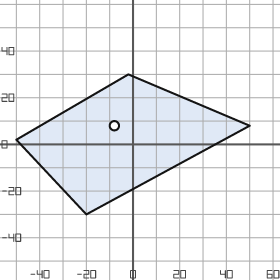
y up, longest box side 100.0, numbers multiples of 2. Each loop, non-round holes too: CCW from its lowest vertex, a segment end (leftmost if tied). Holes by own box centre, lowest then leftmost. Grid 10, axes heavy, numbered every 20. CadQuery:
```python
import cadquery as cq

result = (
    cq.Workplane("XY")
    .moveTo(-20.0, -30.0)
    .lineTo(50.0, 8.0)
    .lineTo(-2.0, 30.0)
    .lineTo(-50.0, 2.0)
    .close()
    .moveTo(-8.0, 8.0)
    .circle(2.0)
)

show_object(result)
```